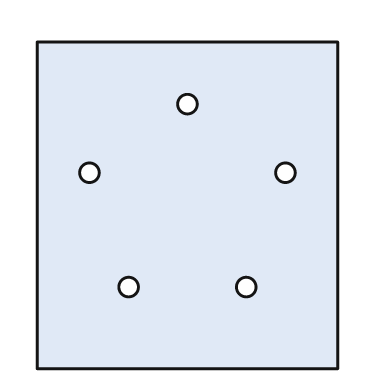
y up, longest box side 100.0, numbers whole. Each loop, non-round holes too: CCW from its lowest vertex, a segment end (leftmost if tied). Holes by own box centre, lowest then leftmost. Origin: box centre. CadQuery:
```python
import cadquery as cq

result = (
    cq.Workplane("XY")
    .moveTo(-46.0, -50.0)
    .lineTo(46.0, -50.0)
    .lineTo(46.0, 50.0)
    .lineTo(-46.0, 50.0)
    .close()
    .moveTo(-18.0, -25.0)
    .circle(3.0)
    .moveTo(18.0, -25.0)
    .circle(3.0)
    .moveTo(-30.0, 10.0)
    .circle(3.0)
    .moveTo(30.0, 10.0)
    .circle(3.0)
    .moveTo(0.0, 31.0)
    .circle(3.0)
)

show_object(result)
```